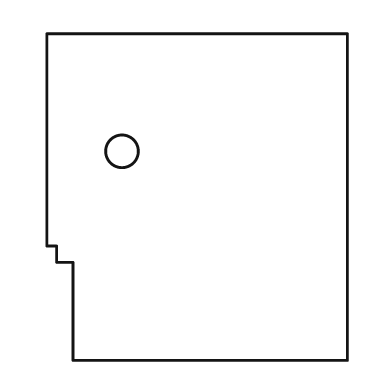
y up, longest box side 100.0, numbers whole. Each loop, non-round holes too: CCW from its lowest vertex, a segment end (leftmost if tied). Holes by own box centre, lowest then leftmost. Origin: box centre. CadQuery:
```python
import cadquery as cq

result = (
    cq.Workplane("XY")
    .moveTo(-38.0, -50.0)
    .lineTo(46.0, -50.0)
    .lineTo(46.0, 50.0)
    .lineTo(-46.0, 50.0)
    .lineTo(-46.0, -15.0)
    .lineTo(-43.0, -15.0)
    .lineTo(-43.0, -20.0)
    .lineTo(-38.0, -20.0)
    .close()
    .moveTo(-23.0, 14.0)
    .circle(5.0)
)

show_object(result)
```